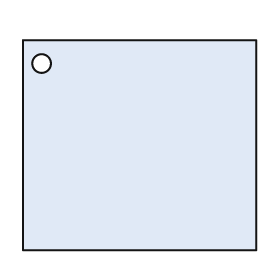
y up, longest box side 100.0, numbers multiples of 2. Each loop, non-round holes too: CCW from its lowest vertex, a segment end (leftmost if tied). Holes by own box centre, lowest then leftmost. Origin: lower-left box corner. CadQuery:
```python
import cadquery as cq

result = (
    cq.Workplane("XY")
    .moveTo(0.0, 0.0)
    .lineTo(100.0, 0.0)
    .lineTo(100.0, 90.0)
    .lineTo(0.0, 90.0)
    .close()
    .moveTo(8.0, 80.0)
    .circle(4.0)
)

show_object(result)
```